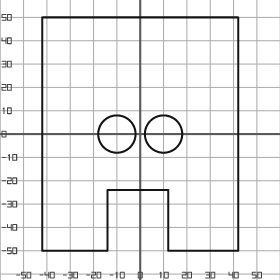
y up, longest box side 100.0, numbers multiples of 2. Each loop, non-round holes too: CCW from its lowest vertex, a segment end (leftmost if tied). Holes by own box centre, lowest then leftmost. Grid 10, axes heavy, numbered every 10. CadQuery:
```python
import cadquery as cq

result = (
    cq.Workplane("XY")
    .moveTo(-42.0, -50.0)
    .lineTo(-14.0, -50.0)
    .lineTo(-14.0, -24.0)
    .lineTo(12.0, -24.0)
    .lineTo(12.0, -50.0)
    .lineTo(42.0, -50.0)
    .lineTo(42.0, 50.0)
    .lineTo(-42.0, 50.0)
    .close()
    .moveTo(-10.0, 0.0)
    .circle(8.0)
    .moveTo(10.0, 0.0)
    .circle(8.0)
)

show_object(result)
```